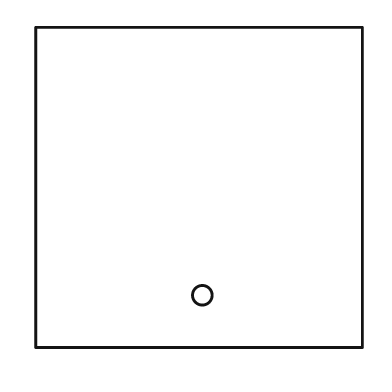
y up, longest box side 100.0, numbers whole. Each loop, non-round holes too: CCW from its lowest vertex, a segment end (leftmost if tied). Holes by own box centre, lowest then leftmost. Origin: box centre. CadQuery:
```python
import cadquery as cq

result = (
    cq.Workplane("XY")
    .moveTo(-50.0, -49.0)
    .lineTo(50.0, -49.0)
    .lineTo(50.0, 49.0)
    .lineTo(-50.0, 49.0)
    .close()
    .moveTo(1.0, -33.0)
    .circle(3.0)
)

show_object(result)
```